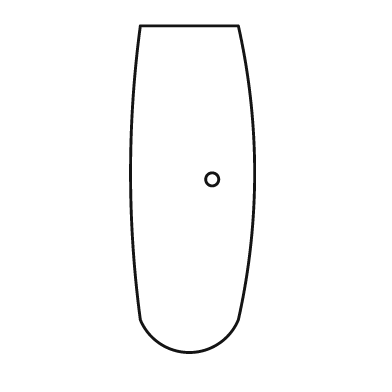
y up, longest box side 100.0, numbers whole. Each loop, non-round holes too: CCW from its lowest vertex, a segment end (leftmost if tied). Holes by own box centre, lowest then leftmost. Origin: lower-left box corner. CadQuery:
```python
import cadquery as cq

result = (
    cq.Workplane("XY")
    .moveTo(3.0, 10.0)
    .threePointArc((18.0, 0.0), (33.0, 10.0))
    .threePointArc((38.0, 55.0), (33.0, 100.0))
    .lineTo(3.0, 100.0)
    .threePointArc((0.0, 55.0), (3.0, 10.0))
    .close()
    .moveTo(25.0, 53.0)
    .circle(2.0)
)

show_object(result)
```